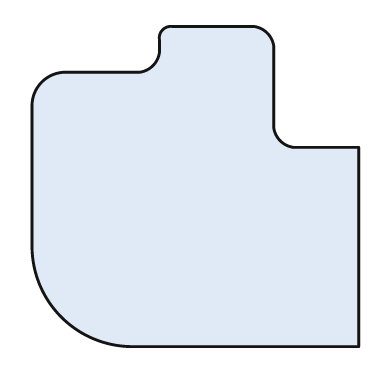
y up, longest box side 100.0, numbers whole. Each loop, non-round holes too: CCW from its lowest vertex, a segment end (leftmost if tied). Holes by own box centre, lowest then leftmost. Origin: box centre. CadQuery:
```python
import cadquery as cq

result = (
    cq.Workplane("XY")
    .moveTo(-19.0, -49.0)
    .lineTo(50.0, -49.0)
    .lineTo(50.0, 12.0)
    .lineTo(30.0, 12.0)
    .threePointArc((26.0, 14.0), (24.0, 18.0))
    .lineTo(24.0, 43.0)
    .threePointArc((22.0, 47.0), (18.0, 49.0))
    .lineTo(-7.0, 49.0)
    .threePointArc((-10.0, 48.0), (-11.0, 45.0))
    .lineTo(-11.0, 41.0)
    .threePointArc((-13.0, 37.0), (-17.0, 35.0))
    .lineTo(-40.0, 35.0)
    .threePointArc((-47.0, 32.0), (-50.0, 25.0))
    .lineTo(-50.0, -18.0)
    .threePointArc((-41.0, -40.0), (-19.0, -49.0))
    .close()
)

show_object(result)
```